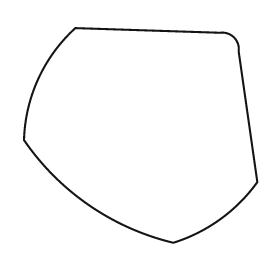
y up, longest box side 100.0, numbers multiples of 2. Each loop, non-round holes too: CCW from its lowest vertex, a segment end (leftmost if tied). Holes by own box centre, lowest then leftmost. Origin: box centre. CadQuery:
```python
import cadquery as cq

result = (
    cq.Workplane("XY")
    .moveTo(14.0, -46.0)
    .threePointArc((34.0, -36.0), (50.0, -20.0))
    .lineTo(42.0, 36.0)
    .threePointArc((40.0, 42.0), (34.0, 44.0))
    .lineTo(-28.0, 46.0)
    .threePointArc((-44.0, 24.0), (-50.0, -2.0))
    .threePointArc((-22.0, -30.0), (14.0, -46.0))
    .close()
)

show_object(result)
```